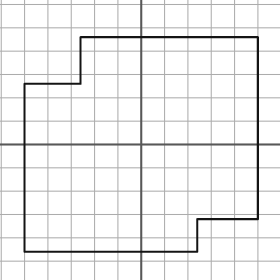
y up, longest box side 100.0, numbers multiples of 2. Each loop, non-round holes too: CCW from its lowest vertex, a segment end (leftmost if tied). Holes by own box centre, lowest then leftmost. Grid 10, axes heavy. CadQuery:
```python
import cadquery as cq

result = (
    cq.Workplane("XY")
    .moveTo(-50.0, -46.0)
    .lineTo(24.0, -46.0)
    .lineTo(24.0, -32.0)
    .lineTo(50.0, -32.0)
    .lineTo(50.0, 46.0)
    .lineTo(-26.0, 46.0)
    .lineTo(-26.0, 26.0)
    .lineTo(-50.0, 26.0)
    .close()
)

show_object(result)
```